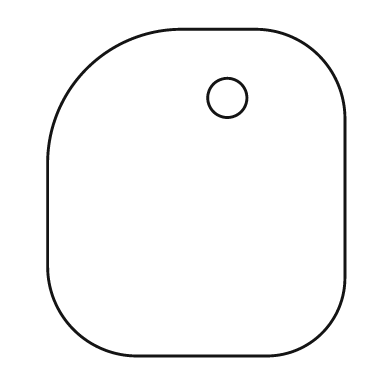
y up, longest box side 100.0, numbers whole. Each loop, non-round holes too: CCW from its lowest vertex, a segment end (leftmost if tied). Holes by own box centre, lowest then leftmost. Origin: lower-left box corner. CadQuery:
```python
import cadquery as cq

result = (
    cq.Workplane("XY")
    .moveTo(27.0, 0.0)
    .lineTo(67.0, 0.0)
    .threePointArc((84.0, 7.0), (91.0, 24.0))
    .lineTo(91.0, 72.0)
    .threePointArc((83.0, 92.0), (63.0, 100.0))
    .lineTo(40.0, 100.0)
    .threePointArc((12.0, 88.0), (0.0, 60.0))
    .lineTo(0.0, 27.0)
    .threePointArc((8.0, 8.0), (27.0, 0.0))
    .close()
    .moveTo(55.0, 79.0)
    .circle(6.0)
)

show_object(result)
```